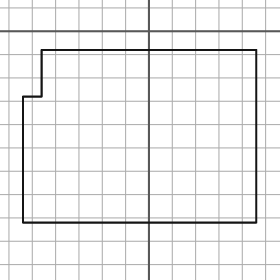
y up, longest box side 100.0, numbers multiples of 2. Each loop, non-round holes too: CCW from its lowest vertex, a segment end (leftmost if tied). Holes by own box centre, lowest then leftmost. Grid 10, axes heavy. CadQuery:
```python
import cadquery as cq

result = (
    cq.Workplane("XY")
    .moveTo(-54.0, -82.0)
    .lineTo(46.0, -82.0)
    .lineTo(46.0, -8.0)
    .lineTo(-46.0, -8.0)
    .lineTo(-46.0, -28.0)
    .lineTo(-54.0, -28.0)
    .close()
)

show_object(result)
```